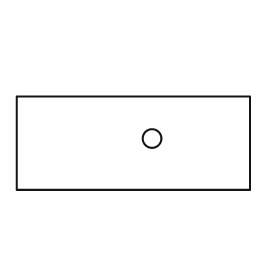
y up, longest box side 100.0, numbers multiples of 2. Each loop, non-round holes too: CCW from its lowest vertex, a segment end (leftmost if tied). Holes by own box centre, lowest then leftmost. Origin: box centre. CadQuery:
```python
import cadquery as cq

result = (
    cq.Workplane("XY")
    .moveTo(-50.0, -20.0)
    .lineTo(50.0, -20.0)
    .lineTo(50.0, 20.0)
    .lineTo(-50.0, 20.0)
    .close()
    .moveTo(8.0, 2.0)
    .circle(4.0)
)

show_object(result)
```